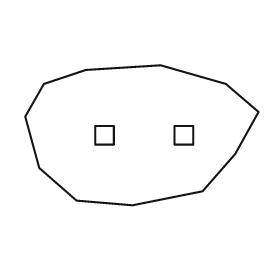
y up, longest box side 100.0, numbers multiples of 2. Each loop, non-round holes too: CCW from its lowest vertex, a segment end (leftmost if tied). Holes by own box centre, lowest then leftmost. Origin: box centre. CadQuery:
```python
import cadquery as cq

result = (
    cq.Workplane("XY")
    .moveTo(-4.0, -30.0)
    .lineTo(26.0, -24.0)
    .lineTo(40.0, -8.0)
    .lineTo(50.0, 10.0)
    .lineTo(36.0, 22.0)
    .lineTo(8.0, 30.0)
    .lineTo(-24.0, 28.0)
    .lineTo(-42.0, 22.0)
    .lineTo(-50.0, 8.0)
    .lineTo(-44.0, -14.0)
    .lineTo(-28.0, -28.0)
    .close()
    .moveTo(-20.0, -4.0)
    .lineTo(-12.0, -4.0)
    .lineTo(-12.0, 4.0)
    .lineTo(-20.0, 4.0)
    .close()
    .moveTo(14.0, -4.0)
    .lineTo(22.0, -4.0)
    .lineTo(22.0, 4.0)
    .lineTo(14.0, 4.0)
    .close()
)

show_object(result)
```